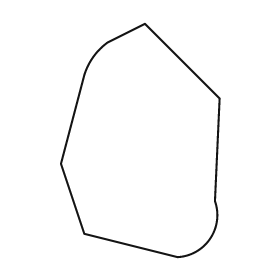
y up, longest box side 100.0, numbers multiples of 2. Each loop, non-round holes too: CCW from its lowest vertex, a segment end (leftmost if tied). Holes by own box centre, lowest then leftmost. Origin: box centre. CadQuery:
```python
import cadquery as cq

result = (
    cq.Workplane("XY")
    .moveTo(16.0, -50.0)
    .threePointArc((30.0, -42.0), (32.0, -26.0))
    .lineTo(34.0, 18.0)
    .lineTo(2.0, 50.0)
    .lineTo(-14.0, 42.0)
    .threePointArc((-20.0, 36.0), (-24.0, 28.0))
    .lineTo(-34.0, -10.0)
    .lineTo(-24.0, -40.0)
    .close()
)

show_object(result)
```